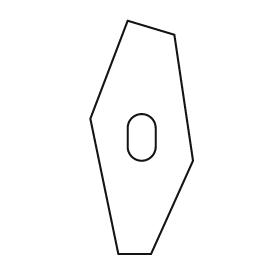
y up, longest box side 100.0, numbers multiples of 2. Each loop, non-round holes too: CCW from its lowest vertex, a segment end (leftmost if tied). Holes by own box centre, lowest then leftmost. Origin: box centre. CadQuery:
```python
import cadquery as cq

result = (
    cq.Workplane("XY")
    .moveTo(-10.0, -50.0)
    .lineTo(4.0, -50.0)
    .lineTo(22.0, -10.0)
    .lineTo(14.0, 44.0)
    .lineTo(-6.0, 50.0)
    .lineTo(-22.0, 8.0)
    .close()
    .moveTo(-6.0, -4.0)
    .threePointArc((0.0, -10.0), (6.0, -4.0))
    .lineTo(6.0, 4.0)
    .threePointArc((0.0, 10.0), (-6.0, 4.0))
    .close()
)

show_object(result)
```